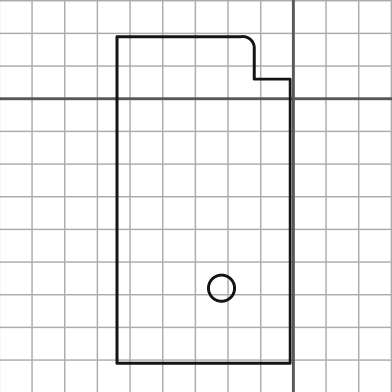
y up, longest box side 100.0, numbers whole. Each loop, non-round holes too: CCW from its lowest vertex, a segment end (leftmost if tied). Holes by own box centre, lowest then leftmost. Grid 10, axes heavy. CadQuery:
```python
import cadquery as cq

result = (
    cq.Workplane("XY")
    .moveTo(-54.0, -81.0)
    .lineTo(-1.0, -81.0)
    .lineTo(-1.0, 6.0)
    .lineTo(-12.0, 6.0)
    .lineTo(-12.0, 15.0)
    .threePointArc((-13.0, 18.0), (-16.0, 19.0))
    .lineTo(-54.0, 19.0)
    .close()
    .moveTo(-22.0, -58.0)
    .circle(4.0)
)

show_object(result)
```